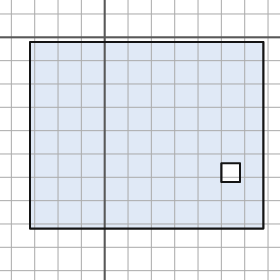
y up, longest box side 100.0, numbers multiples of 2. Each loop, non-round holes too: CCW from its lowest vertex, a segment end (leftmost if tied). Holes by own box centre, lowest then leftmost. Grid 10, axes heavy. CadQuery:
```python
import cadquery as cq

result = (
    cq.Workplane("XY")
    .moveTo(-32.0, -82.0)
    .lineTo(68.0, -82.0)
    .lineTo(68.0, -2.0)
    .lineTo(-32.0, -2.0)
    .close()
    .moveTo(50.0, -62.0)
    .lineTo(58.0, -62.0)
    .lineTo(58.0, -54.0)
    .lineTo(50.0, -54.0)
    .close()
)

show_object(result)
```